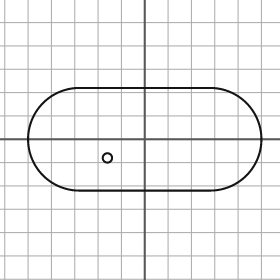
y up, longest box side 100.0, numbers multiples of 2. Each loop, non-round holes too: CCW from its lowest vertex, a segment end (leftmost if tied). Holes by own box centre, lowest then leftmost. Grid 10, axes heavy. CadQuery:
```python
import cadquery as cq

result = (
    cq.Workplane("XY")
    .moveTo(-28.0, -22.0)
    .lineTo(28.0, -22.0)
    .threePointArc((50.0, 0.0), (28.0, 22.0))
    .lineTo(-28.0, 22.0)
    .threePointArc((-50.0, 0.0), (-28.0, -22.0))
    .close()
    .moveTo(-16.0, -8.0)
    .circle(2.0)
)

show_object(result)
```